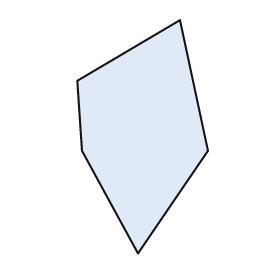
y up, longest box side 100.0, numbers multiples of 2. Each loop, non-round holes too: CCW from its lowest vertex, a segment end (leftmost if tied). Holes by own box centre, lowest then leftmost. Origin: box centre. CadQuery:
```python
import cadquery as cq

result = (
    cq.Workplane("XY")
    .moveTo(-2.0, -50.0)
    .lineTo(28.0, -6.0)
    .lineTo(16.0, 50.0)
    .lineTo(-28.0, 24.0)
    .lineTo(-26.0, -6.0)
    .close()
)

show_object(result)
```